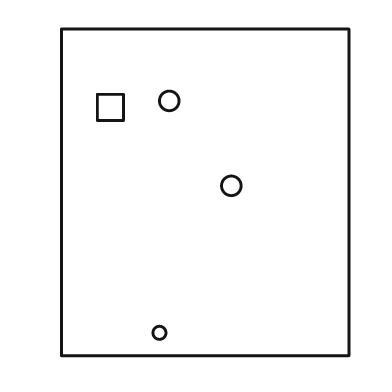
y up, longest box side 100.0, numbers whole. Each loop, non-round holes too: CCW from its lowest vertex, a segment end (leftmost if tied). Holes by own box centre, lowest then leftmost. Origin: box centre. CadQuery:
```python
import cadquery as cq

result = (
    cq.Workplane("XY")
    .moveTo(-44.0, -50.0)
    .lineTo(44.0, -50.0)
    .lineTo(44.0, 50.0)
    .lineTo(-44.0, 50.0)
    .close()
    .moveTo(-14.0, -43.0)
    .circle(2.0)
    .moveTo(8.0, 2.0)
    .circle(3.0)
    .moveTo(-33.0, 22.0)
    .lineTo(-25.0, 22.0)
    .lineTo(-25.0, 30.0)
    .lineTo(-33.0, 30.0)
    .close()
    .moveTo(-11.0, 28.0)
    .circle(3.0)
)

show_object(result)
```